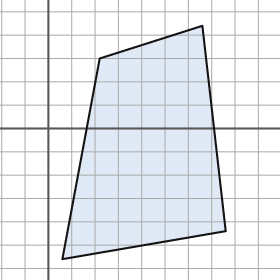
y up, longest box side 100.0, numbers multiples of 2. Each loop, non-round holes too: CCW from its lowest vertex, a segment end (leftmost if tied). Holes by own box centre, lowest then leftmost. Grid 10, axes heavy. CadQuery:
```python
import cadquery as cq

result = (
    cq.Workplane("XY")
    .moveTo(6.0, -56.0)
    .lineTo(76.0, -44.0)
    .lineTo(66.0, 44.0)
    .lineTo(22.0, 30.0)
    .close()
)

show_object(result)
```